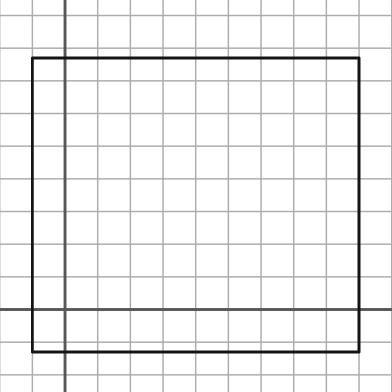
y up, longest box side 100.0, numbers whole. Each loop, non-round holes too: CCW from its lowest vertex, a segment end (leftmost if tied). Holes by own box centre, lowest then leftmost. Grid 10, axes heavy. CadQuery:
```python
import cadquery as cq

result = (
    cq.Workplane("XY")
    .moveTo(-10.0, -13.0)
    .lineTo(90.0, -13.0)
    .lineTo(90.0, 77.0)
    .lineTo(-10.0, 77.0)
    .close()
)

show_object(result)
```